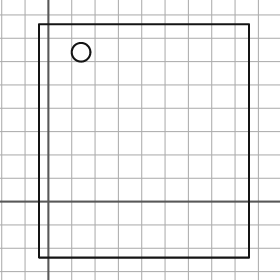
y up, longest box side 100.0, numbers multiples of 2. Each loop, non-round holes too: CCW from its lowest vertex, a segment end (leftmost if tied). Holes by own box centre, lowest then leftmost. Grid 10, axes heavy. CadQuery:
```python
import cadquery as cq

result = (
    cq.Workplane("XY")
    .moveTo(-4.0, -24.0)
    .lineTo(86.0, -24.0)
    .lineTo(86.0, 76.0)
    .lineTo(-4.0, 76.0)
    .close()
    .moveTo(14.0, 64.0)
    .circle(4.0)
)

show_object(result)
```